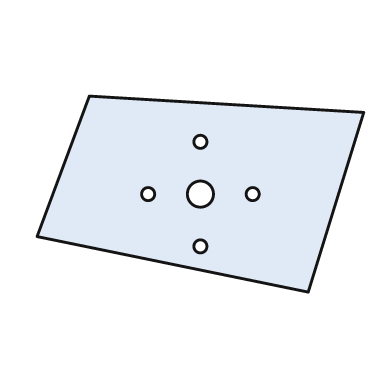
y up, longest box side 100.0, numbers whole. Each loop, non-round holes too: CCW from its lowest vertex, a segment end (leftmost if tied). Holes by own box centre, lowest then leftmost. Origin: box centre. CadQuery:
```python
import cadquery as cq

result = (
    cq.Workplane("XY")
    .moveTo(33.0, -30.0)
    .lineTo(50.0, 25.0)
    .lineTo(-34.0, 30.0)
    .lineTo(-50.0, -13.0)
    .close()
    .moveTo(0.0, -16.0)
    .circle(2.0)
    .moveTo(-16.0, 0.0)
    .circle(2.0)
    .moveTo(0.0, 0.0)
    .circle(4.0)
    .moveTo(16.0, 0.0)
    .circle(2.0)
    .moveTo(0.0, 16.0)
    .circle(2.0)
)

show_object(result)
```